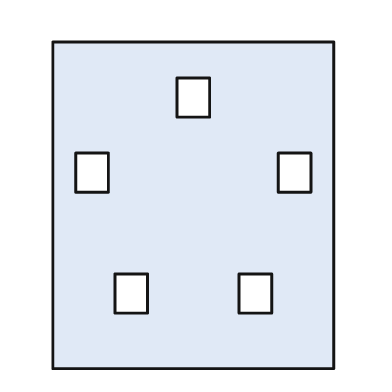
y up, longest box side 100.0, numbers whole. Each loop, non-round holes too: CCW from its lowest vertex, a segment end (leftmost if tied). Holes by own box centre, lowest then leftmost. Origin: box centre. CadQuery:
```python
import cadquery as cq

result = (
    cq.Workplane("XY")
    .moveTo(-43.0, -50.0)
    .lineTo(43.0, -50.0)
    .lineTo(43.0, 50.0)
    .lineTo(-43.0, 50.0)
    .close()
    .moveTo(-24.0, -33.0)
    .lineTo(-14.0, -33.0)
    .lineTo(-14.0, -21.0)
    .lineTo(-24.0, -21.0)
    .close()
    .moveTo(14.0, -33.0)
    .lineTo(24.0, -33.0)
    .lineTo(24.0, -21.0)
    .lineTo(14.0, -21.0)
    .close()
    .moveTo(-36.0, 4.0)
    .lineTo(-26.0, 4.0)
    .lineTo(-26.0, 16.0)
    .lineTo(-36.0, 16.0)
    .close()
    .moveTo(26.0, 4.0)
    .lineTo(36.0, 4.0)
    .lineTo(36.0, 16.0)
    .lineTo(26.0, 16.0)
    .close()
    .moveTo(-5.0, 27.0)
    .lineTo(5.0, 27.0)
    .lineTo(5.0, 39.0)
    .lineTo(-5.0, 39.0)
    .close()
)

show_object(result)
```